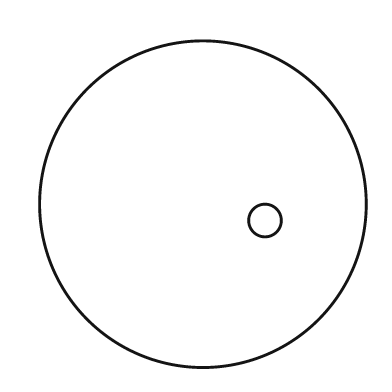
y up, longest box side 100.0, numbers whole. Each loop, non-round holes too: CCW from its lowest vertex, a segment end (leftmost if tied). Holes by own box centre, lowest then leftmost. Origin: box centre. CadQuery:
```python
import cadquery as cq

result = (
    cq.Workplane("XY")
    .moveTo(0.0, 0.0)
    .circle(50.0)
    .moveTo(19.0, -5.0)
    .circle(5.0)
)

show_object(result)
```